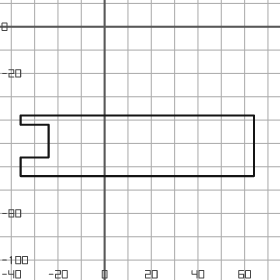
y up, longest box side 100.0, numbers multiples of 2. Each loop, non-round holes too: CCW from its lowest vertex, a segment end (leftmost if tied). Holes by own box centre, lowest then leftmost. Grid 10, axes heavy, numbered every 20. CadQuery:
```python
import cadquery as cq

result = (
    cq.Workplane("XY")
    .moveTo(-36.0, -64.0)
    .lineTo(64.0, -64.0)
    .lineTo(64.0, -38.0)
    .lineTo(-36.0, -38.0)
    .lineTo(-36.0, -42.0)
    .lineTo(-24.0, -42.0)
    .lineTo(-24.0, -56.0)
    .lineTo(-36.0, -56.0)
    .close()
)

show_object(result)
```